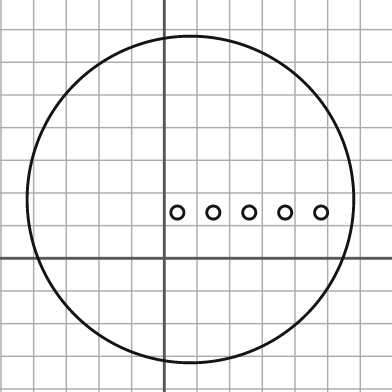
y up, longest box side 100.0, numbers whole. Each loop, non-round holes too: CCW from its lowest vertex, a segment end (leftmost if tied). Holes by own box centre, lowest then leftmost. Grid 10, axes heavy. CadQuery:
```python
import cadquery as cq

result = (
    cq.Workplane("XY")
    .moveTo(8.0, 18.0)
    .circle(50.0)
    .moveTo(4.0, 14.0)
    .circle(2.0)
    .moveTo(15.0, 14.0)
    .circle(2.0)
    .moveTo(26.0, 14.0)
    .circle(2.0)
    .moveTo(37.0, 14.0)
    .circle(2.0)
    .moveTo(48.0, 14.0)
    .circle(2.0)
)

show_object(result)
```